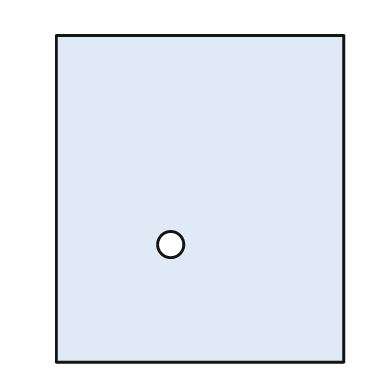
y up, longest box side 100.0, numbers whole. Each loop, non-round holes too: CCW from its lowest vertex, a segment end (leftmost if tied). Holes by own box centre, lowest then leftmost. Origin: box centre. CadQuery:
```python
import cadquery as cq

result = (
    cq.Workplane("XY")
    .moveTo(-44.0, -50.0)
    .lineTo(44.0, -50.0)
    .lineTo(44.0, 50.0)
    .lineTo(-44.0, 50.0)
    .close()
    .moveTo(-9.0, -14.0)
    .circle(4.0)
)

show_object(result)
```